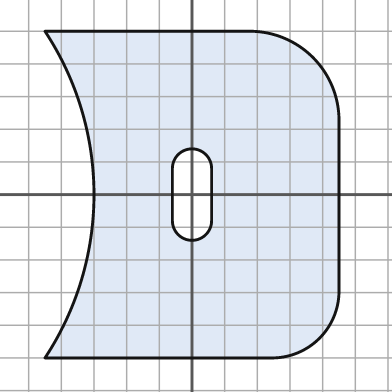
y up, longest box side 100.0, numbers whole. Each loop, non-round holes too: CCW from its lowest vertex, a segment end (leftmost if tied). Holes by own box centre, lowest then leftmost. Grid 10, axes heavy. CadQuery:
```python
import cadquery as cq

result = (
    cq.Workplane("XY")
    .moveTo(-45.0, -50.0)
    .lineTo(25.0, -50.0)
    .threePointArc((39.0, -44.0), (45.0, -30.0))
    .lineTo(45.0, 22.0)
    .threePointArc((37.0, 42.0), (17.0, 50.0))
    .lineTo(-45.0, 50.0)
    .threePointArc((-30.0, 0.0), (-45.0, -50.0))
    .close()
    .moveTo(-6.0, -8.0)
    .threePointArc((0.0, -14.0), (6.0, -8.0))
    .lineTo(6.0, 8.0)
    .threePointArc((0.0, 14.0), (-6.0, 8.0))
    .close()
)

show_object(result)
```